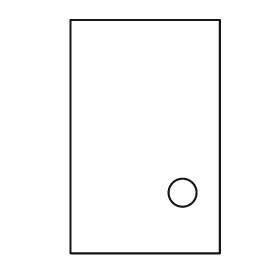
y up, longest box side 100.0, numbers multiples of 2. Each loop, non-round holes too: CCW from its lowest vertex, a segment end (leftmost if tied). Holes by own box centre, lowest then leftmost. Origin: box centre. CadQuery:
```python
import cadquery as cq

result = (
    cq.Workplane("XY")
    .moveTo(-32.0, -50.0)
    .lineTo(32.0, -50.0)
    .lineTo(32.0, 50.0)
    .lineTo(-32.0, 50.0)
    .close()
    .moveTo(16.0, -24.0)
    .circle(6.0)
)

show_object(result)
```